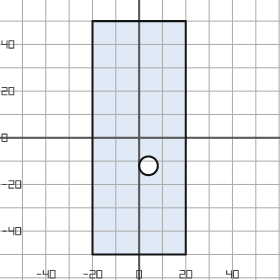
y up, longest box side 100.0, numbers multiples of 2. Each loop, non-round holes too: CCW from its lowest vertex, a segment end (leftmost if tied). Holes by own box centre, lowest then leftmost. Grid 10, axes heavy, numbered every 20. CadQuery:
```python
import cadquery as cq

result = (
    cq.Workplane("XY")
    .moveTo(-20.0, -50.0)
    .lineTo(20.0, -50.0)
    .lineTo(20.0, 50.0)
    .lineTo(-20.0, 50.0)
    .close()
    .moveTo(4.0, -12.0)
    .circle(4.0)
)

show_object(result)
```